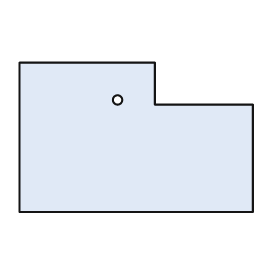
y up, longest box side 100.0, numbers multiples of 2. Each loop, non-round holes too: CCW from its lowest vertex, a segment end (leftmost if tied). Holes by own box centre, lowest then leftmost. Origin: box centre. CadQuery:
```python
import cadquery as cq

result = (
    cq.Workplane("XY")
    .moveTo(-50.0, -32.0)
    .lineTo(50.0, -32.0)
    .lineTo(50.0, 14.0)
    .lineTo(8.0, 14.0)
    .lineTo(8.0, 32.0)
    .lineTo(-50.0, 32.0)
    .close()
    .moveTo(-8.0, 16.0)
    .circle(2.0)
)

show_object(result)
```